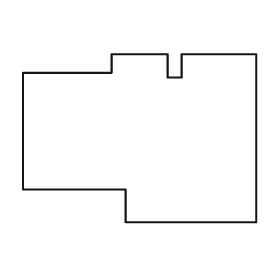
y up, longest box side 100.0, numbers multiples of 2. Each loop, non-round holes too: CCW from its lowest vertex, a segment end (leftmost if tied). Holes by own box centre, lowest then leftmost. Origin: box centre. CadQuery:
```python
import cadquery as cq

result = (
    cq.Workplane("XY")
    .moveTo(-6.0, -36.0)
    .lineTo(50.0, -36.0)
    .lineTo(50.0, 36.0)
    .lineTo(18.0, 36.0)
    .lineTo(18.0, 26.0)
    .lineTo(12.0, 26.0)
    .lineTo(12.0, 36.0)
    .lineTo(-12.0, 36.0)
    .lineTo(-12.0, 28.0)
    .lineTo(-50.0, 28.0)
    .lineTo(-50.0, -22.0)
    .lineTo(-6.0, -22.0)
    .close()
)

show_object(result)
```